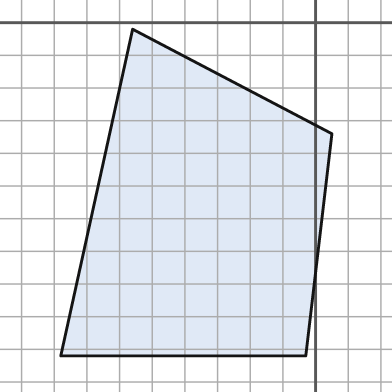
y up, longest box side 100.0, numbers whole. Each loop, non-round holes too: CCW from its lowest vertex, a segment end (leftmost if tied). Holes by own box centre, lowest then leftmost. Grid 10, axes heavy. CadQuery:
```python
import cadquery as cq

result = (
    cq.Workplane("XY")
    .moveTo(-78.0, -102.0)
    .lineTo(-3.0, -102.0)
    .lineTo(5.0, -34.0)
    .lineTo(-56.0, -2.0)
    .close()
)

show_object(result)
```